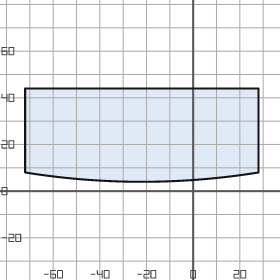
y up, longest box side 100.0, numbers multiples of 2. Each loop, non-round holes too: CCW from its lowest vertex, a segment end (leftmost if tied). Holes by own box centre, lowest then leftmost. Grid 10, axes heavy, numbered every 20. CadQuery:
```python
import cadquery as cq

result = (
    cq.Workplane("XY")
    .moveTo(-72.0, 8.0)
    .threePointArc((-22.0, 4.0), (28.0, 8.0))
    .lineTo(28.0, 44.0)
    .lineTo(-72.0, 44.0)
    .close()
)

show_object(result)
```